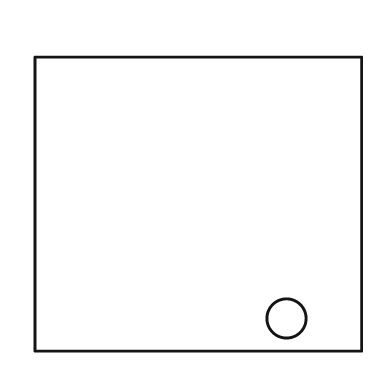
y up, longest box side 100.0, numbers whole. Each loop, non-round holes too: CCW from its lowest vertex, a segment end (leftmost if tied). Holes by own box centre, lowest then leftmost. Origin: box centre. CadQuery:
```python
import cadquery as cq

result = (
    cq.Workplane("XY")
    .moveTo(-50.0, -45.0)
    .lineTo(50.0, -45.0)
    .lineTo(50.0, 45.0)
    .lineTo(-50.0, 45.0)
    .close()
    .moveTo(27.0, -35.0)
    .circle(6.0)
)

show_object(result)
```